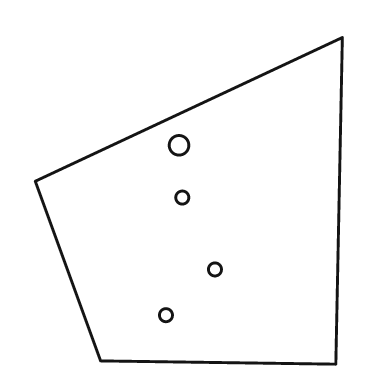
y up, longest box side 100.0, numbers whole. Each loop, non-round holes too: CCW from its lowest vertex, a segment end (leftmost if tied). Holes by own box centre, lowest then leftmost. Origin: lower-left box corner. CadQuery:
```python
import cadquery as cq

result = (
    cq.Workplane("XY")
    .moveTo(92.0, 0.0)
    .lineTo(94.0, 100.0)
    .lineTo(0.0, 56.0)
    .lineTo(20.0, 1.0)
    .close()
    .moveTo(40.0, 15.0)
    .circle(2.0)
    .moveTo(55.0, 29.0)
    .circle(2.0)
    .moveTo(45.0, 51.0)
    .circle(2.0)
    .moveTo(44.0, 67.0)
    .circle(3.0)
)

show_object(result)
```